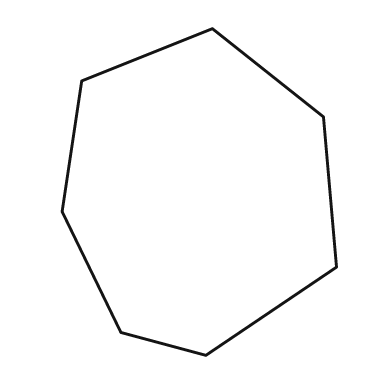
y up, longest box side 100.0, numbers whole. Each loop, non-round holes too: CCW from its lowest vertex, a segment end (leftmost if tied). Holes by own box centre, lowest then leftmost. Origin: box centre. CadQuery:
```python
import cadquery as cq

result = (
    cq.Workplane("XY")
    .moveTo(2.0, -50.0)
    .lineTo(42.0, -23.0)
    .lineTo(38.0, 23.0)
    .lineTo(4.0, 50.0)
    .lineTo(-36.0, 34.0)
    .lineTo(-42.0, -6.0)
    .lineTo(-24.0, -43.0)
    .close()
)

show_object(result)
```